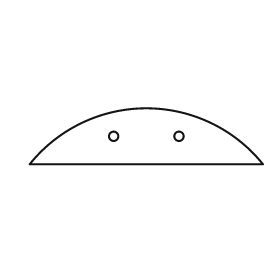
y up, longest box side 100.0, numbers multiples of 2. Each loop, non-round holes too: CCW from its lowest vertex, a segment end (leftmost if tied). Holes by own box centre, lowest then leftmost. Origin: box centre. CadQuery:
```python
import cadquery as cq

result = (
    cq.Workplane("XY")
    .moveTo(-50.0, -12.0)
    .lineTo(50.0, -12.0)
    .threePointArc((0.0, 12.0), (-50.0, -12.0))
    .close()
    .moveTo(-14.0, 0.0)
    .circle(2.0)
    .moveTo(14.0, 0.0)
    .circle(2.0)
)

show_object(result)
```